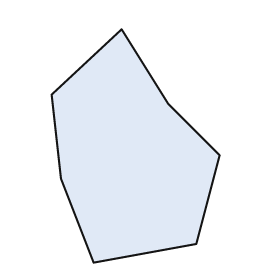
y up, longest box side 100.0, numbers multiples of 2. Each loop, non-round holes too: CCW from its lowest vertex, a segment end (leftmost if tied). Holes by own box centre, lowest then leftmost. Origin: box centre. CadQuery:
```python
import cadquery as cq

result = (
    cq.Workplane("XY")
    .moveTo(-18.0, -50.0)
    .lineTo(26.0, -42.0)
    .lineTo(36.0, -4.0)
    .lineTo(14.0, 18.0)
    .lineTo(-6.0, 50.0)
    .lineTo(-36.0, 22.0)
    .lineTo(-32.0, -14.0)
    .close()
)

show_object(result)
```